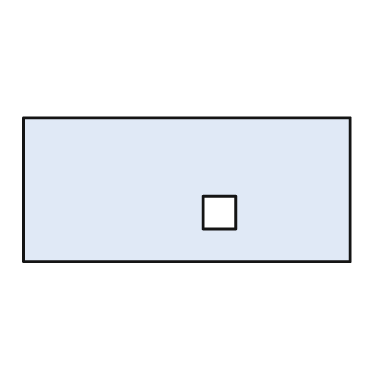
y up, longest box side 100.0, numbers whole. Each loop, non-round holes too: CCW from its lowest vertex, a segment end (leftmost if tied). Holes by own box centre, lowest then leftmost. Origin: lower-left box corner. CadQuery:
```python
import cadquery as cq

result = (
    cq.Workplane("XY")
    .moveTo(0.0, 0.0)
    .lineTo(100.0, 0.0)
    .lineTo(100.0, 44.0)
    .lineTo(0.0, 44.0)
    .close()
    .moveTo(55.0, 10.0)
    .lineTo(65.0, 10.0)
    .lineTo(65.0, 20.0)
    .lineTo(55.0, 20.0)
    .close()
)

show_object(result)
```